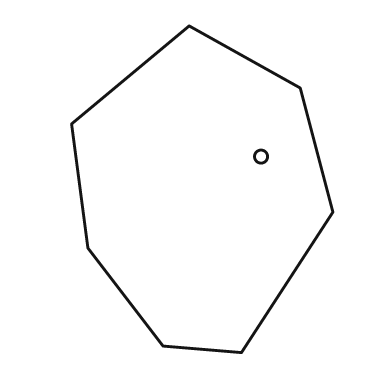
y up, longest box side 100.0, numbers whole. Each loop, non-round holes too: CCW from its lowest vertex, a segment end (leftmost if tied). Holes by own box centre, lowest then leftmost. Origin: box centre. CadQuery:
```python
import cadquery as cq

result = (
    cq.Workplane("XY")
    .moveTo(12.0, -50.0)
    .lineTo(40.0, -7.0)
    .lineTo(30.0, 31.0)
    .lineTo(-4.0, 50.0)
    .lineTo(-40.0, 20.0)
    .lineTo(-35.0, -18.0)
    .lineTo(-12.0, -48.0)
    .close()
    .moveTo(18.0, 10.0)
    .circle(2.0)
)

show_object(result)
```